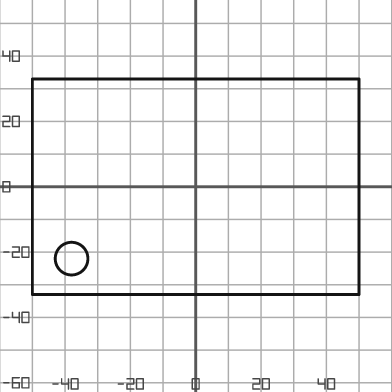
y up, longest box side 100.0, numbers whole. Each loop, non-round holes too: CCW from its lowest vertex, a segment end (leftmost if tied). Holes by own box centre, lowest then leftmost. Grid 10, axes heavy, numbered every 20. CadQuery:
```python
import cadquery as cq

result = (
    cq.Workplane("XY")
    .moveTo(-50.0, -33.0)
    .lineTo(50.0, -33.0)
    .lineTo(50.0, 33.0)
    .lineTo(-50.0, 33.0)
    .close()
    .moveTo(-38.0, -22.0)
    .circle(5.0)
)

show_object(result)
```